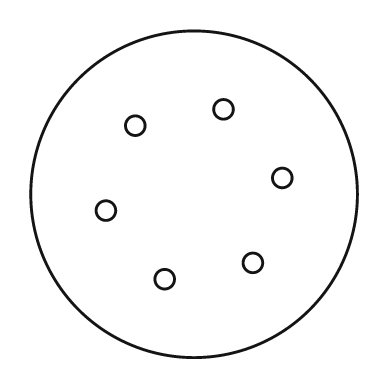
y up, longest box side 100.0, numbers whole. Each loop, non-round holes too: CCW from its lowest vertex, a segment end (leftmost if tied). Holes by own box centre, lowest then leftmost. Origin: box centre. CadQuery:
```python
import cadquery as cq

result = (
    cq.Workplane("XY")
    .moveTo(0.0, 0.0)
    .circle(50.0)
    .moveTo(-9.0, -26.0)
    .circle(3.0)
    .moveTo(18.0, -21.0)
    .circle(3.0)
    .moveTo(-27.0, -5.0)
    .circle(3.0)
    .moveTo(27.0, 5.0)
    .circle(3.0)
    .moveTo(-18.0, 21.0)
    .circle(3.0)
    .moveTo(9.0, 26.0)
    .circle(3.0)
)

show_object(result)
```